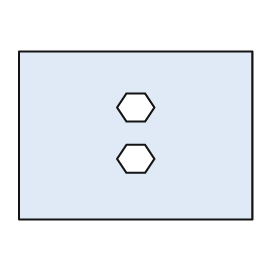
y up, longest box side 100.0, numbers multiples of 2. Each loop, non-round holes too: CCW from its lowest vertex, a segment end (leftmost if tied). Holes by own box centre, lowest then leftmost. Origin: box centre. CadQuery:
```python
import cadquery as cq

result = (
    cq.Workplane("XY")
    .moveTo(-50.0, -36.0)
    .lineTo(50.0, -36.0)
    .lineTo(50.0, 36.0)
    .lineTo(-50.0, 36.0)
    .close()
    .moveTo(-4.0, -16.0)
    .lineTo(4.0, -16.0)
    .lineTo(8.0, -10.0)
    .lineTo(4.0, -4.0)
    .lineTo(-4.0, -4.0)
    .lineTo(-8.0, -10.0)
    .close()
    .moveTo(-4.0, 6.0)
    .lineTo(4.0, 6.0)
    .lineTo(8.0, 12.0)
    .lineTo(4.0, 18.0)
    .lineTo(-4.0, 18.0)
    .lineTo(-8.0, 12.0)
    .close()
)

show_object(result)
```